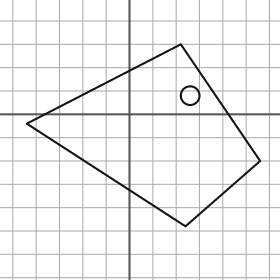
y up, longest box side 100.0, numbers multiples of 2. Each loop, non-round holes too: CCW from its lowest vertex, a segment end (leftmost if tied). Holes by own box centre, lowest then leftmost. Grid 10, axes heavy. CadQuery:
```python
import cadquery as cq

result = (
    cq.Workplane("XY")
    .moveTo(24.0, -48.0)
    .lineTo(56.0, -20.0)
    .lineTo(22.0, 30.0)
    .lineTo(-44.0, -4.0)
    .close()
    .moveTo(26.0, 8.0)
    .circle(4.0)
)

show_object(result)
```